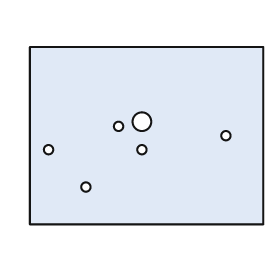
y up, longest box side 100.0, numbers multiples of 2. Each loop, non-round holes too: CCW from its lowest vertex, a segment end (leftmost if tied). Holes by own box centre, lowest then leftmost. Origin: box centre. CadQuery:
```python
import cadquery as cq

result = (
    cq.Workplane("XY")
    .moveTo(-50.0, -38.0)
    .lineTo(50.0, -38.0)
    .lineTo(50.0, 38.0)
    .lineTo(-50.0, 38.0)
    .close()
    .moveTo(-26.0, -22.0)
    .circle(2.0)
    .moveTo(-42.0, -6.0)
    .circle(2.0)
    .moveTo(-2.0, -6.0)
    .circle(2.0)
    .moveTo(34.0, 0.0)
    .circle(2.0)
    .moveTo(-12.0, 4.0)
    .circle(2.0)
    .moveTo(-2.0, 6.0)
    .circle(4.0)
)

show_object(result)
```